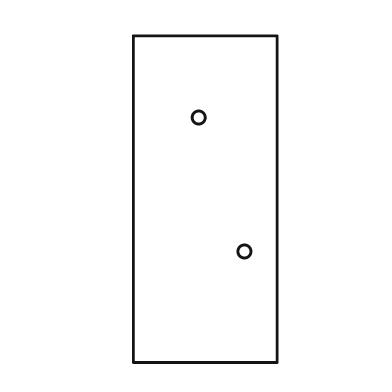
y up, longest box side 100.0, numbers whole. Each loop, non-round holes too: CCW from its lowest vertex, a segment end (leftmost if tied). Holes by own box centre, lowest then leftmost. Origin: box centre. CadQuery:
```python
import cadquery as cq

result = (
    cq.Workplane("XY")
    .moveTo(-22.0, -50.0)
    .lineTo(22.0, -50.0)
    .lineTo(22.0, 50.0)
    .lineTo(-22.0, 50.0)
    .close()
    .moveTo(12.0, -16.0)
    .circle(2.0)
    .moveTo(-2.0, 25.0)
    .circle(2.0)
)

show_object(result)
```